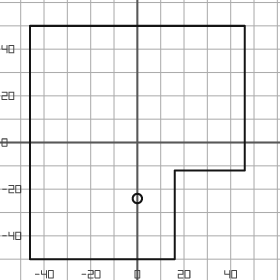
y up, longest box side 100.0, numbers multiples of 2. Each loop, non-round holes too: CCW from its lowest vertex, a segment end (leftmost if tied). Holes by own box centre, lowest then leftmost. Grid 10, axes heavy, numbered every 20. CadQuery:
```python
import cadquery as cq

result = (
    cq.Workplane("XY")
    .moveTo(-46.0, -50.0)
    .lineTo(16.0, -50.0)
    .lineTo(16.0, -12.0)
    .lineTo(46.0, -12.0)
    .lineTo(46.0, 50.0)
    .lineTo(-46.0, 50.0)
    .close()
    .moveTo(0.0, -24.0)
    .circle(2.0)
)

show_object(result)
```